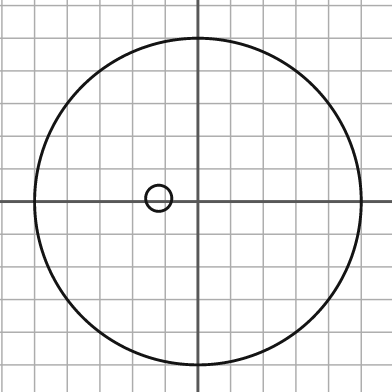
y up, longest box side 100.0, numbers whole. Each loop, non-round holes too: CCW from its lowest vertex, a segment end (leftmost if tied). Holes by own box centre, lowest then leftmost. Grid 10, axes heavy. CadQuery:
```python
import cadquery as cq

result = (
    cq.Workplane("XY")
    .moveTo(0.0, 0.0)
    .circle(50.0)
    .moveTo(-12.0, 1.0)
    .circle(4.0)
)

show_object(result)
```